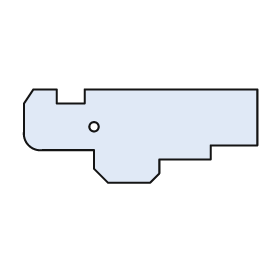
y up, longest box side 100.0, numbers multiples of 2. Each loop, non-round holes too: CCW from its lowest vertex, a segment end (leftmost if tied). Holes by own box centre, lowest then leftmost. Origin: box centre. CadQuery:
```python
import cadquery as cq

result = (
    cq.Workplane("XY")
    .moveTo(-14.0, -20.0)
    .lineTo(4.0, -20.0)
    .lineTo(8.0, -16.0)
    .lineTo(8.0, -10.0)
    .lineTo(30.0, -10.0)
    .lineTo(30.0, -4.0)
    .lineTo(50.0, -4.0)
    .lineTo(50.0, 20.0)
    .lineTo(-24.0, 20.0)
    .lineTo(-24.0, 14.0)
    .lineTo(-36.0, 14.0)
    .lineTo(-36.0, 20.0)
    .lineTo(-46.0, 20.0)
    .lineTo(-50.0, 14.0)
    .lineTo(-50.0, 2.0)
    .threePointArc((-48.0, -4.0), (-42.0, -6.0))
    .lineTo(-20.0, -6.0)
    .lineTo(-20.0, -14.0)
    .close()
    .moveTo(-20.0, 4.0)
    .circle(2.0)
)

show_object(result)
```